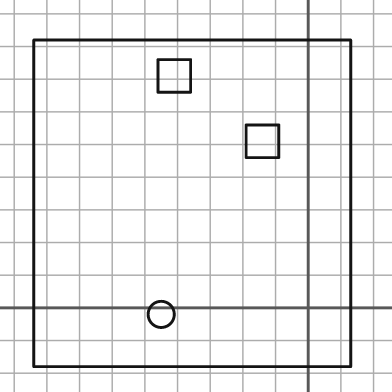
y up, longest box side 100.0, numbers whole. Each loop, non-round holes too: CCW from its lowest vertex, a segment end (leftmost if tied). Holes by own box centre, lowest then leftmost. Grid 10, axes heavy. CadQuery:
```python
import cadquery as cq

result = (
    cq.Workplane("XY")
    .moveTo(-84.0, -18.0)
    .lineTo(13.0, -18.0)
    .lineTo(13.0, 82.0)
    .lineTo(-84.0, 82.0)
    .close()
    .moveTo(-45.0, -2.0)
    .circle(4.0)
    .moveTo(-19.0, 46.0)
    .lineTo(-9.0, 46.0)
    .lineTo(-9.0, 56.0)
    .lineTo(-19.0, 56.0)
    .close()
    .moveTo(-46.0, 66.0)
    .lineTo(-36.0, 66.0)
    .lineTo(-36.0, 76.0)
    .lineTo(-46.0, 76.0)
    .close()
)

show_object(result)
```